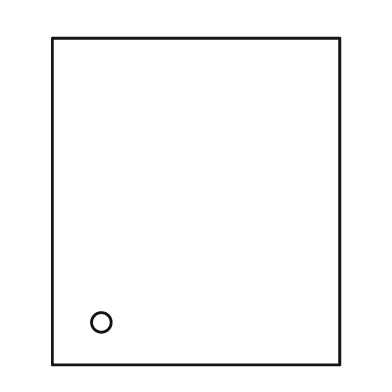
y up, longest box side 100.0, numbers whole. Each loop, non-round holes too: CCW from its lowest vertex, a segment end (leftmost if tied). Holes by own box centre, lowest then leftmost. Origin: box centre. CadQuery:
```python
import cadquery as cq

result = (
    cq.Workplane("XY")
    .moveTo(-44.0, -50.0)
    .lineTo(44.0, -50.0)
    .lineTo(44.0, 50.0)
    .lineTo(-44.0, 50.0)
    .close()
    .moveTo(-29.0, -37.0)
    .circle(3.0)
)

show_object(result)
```